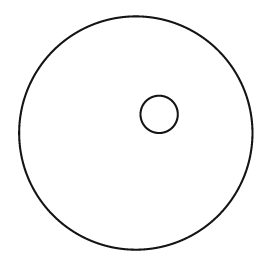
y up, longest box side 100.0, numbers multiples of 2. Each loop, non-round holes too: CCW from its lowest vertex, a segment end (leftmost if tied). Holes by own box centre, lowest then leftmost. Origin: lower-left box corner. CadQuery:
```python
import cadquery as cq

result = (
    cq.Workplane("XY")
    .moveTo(50.0, 50.0)
    .circle(50.0)
    .moveTo(60.0, 58.0)
    .circle(8.0)
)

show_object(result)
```